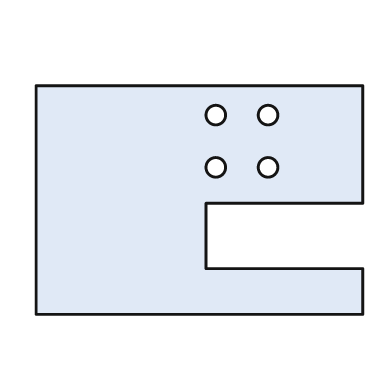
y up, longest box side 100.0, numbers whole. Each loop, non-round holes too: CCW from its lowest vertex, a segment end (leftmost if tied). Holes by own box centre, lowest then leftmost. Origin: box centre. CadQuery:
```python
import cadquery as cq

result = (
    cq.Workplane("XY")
    .moveTo(-50.0, -35.0)
    .lineTo(50.0, -35.0)
    .lineTo(50.0, -21.0)
    .lineTo(2.0, -21.0)
    .lineTo(2.0, -1.0)
    .lineTo(50.0, -1.0)
    .lineTo(50.0, 35.0)
    .lineTo(-50.0, 35.0)
    .close()
    .moveTo(5.0, 10.0)
    .circle(3.0)
    .moveTo(21.0, 10.0)
    .circle(3.0)
    .moveTo(5.0, 26.0)
    .circle(3.0)
    .moveTo(21.0, 26.0)
    .circle(3.0)
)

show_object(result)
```